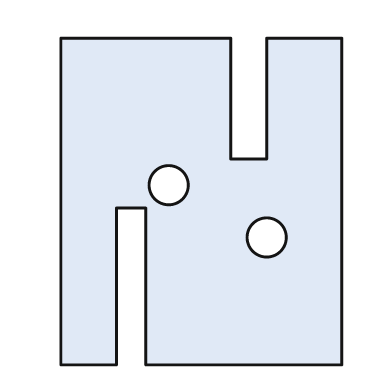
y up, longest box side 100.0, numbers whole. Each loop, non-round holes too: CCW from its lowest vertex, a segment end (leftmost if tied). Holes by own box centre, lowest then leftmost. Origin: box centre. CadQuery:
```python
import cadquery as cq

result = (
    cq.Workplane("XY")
    .moveTo(-43.0, -50.0)
    .lineTo(-26.0, -50.0)
    .lineTo(-26.0, -2.0)
    .lineTo(-17.0, -2.0)
    .lineTo(-17.0, -50.0)
    .lineTo(43.0, -50.0)
    .lineTo(43.0, 50.0)
    .lineTo(20.0, 50.0)
    .lineTo(20.0, 13.0)
    .lineTo(9.0, 13.0)
    .lineTo(9.0, 50.0)
    .lineTo(-43.0, 50.0)
    .close()
    .moveTo(20.0, -11.0)
    .circle(6.0)
    .moveTo(-10.0, 5.0)
    .circle(6.0)
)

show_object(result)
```